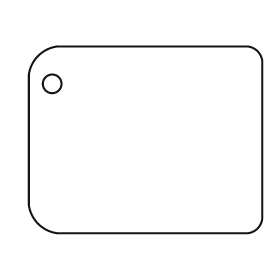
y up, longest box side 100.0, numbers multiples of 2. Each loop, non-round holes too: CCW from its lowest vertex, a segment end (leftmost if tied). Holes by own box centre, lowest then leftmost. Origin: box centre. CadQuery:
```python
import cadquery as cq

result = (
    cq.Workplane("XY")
    .moveTo(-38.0, -40.0)
    .lineTo(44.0, -40.0)
    .threePointArc((48.0, -38.0), (50.0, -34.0))
    .lineTo(50.0, 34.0)
    .threePointArc((48.0, 38.0), (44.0, 40.0))
    .lineTo(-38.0, 40.0)
    .threePointArc((-46.0, 36.0), (-50.0, 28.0))
    .lineTo(-50.0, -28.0)
    .threePointArc((-46.0, -36.0), (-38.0, -40.0))
    .close()
    .moveTo(-40.0, 24.0)
    .circle(4.0)
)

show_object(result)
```